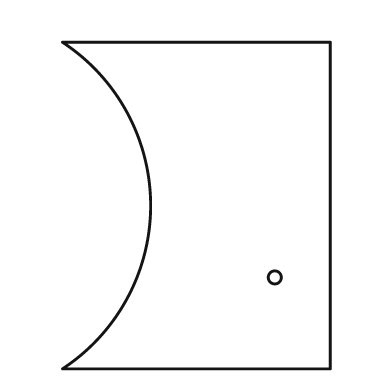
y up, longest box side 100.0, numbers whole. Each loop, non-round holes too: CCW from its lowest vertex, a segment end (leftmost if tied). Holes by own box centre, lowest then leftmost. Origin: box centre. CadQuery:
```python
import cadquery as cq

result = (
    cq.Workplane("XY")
    .moveTo(-41.0, -50.0)
    .lineTo(41.0, -50.0)
    .lineTo(41.0, 50.0)
    .lineTo(-41.0, 50.0)
    .threePointArc((-14.0, 0.0), (-41.0, -50.0))
    .close()
    .moveTo(24.0, -22.0)
    .circle(2.0)
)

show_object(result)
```